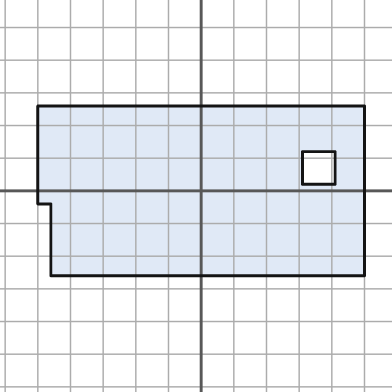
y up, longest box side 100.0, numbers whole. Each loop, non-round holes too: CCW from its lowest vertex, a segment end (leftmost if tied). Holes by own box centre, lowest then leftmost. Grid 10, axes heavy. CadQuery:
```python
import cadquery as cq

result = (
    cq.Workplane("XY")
    .moveTo(-46.0, -26.0)
    .lineTo(50.0, -26.0)
    .lineTo(50.0, 26.0)
    .lineTo(-50.0, 26.0)
    .lineTo(-50.0, -4.0)
    .lineTo(-46.0, -4.0)
    .close()
    .moveTo(31.0, 2.0)
    .lineTo(41.0, 2.0)
    .lineTo(41.0, 12.0)
    .lineTo(31.0, 12.0)
    .close()
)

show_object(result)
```